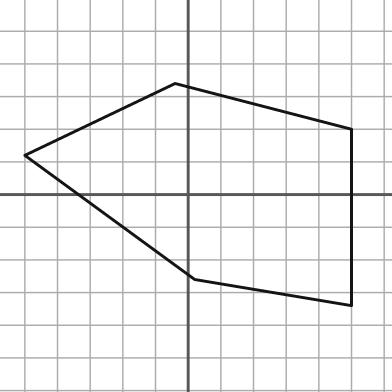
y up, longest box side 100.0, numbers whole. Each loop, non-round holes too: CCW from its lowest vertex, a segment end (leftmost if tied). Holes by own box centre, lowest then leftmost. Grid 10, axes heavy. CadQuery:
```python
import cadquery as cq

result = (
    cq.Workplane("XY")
    .moveTo(50.0, -34.0)
    .lineTo(50.0, 20.0)
    .lineTo(-4.0, 34.0)
    .lineTo(-50.0, 12.0)
    .lineTo(2.0, -26.0)
    .close()
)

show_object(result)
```